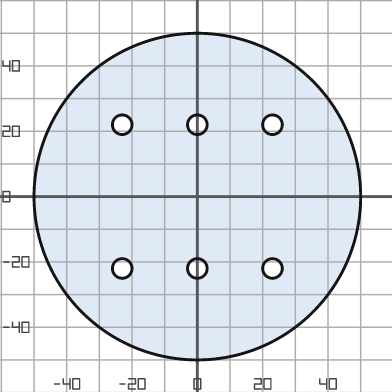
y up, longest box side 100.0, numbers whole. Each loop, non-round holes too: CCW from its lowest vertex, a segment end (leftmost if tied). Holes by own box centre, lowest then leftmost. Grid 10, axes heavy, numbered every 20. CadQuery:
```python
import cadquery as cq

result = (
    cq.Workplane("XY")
    .moveTo(0.0, 0.0)
    .circle(50.0)
    .moveTo(-23.0, -22.0)
    .circle(3.0)
    .moveTo(0.0, -22.0)
    .circle(3.0)
    .moveTo(23.0, -22.0)
    .circle(3.0)
    .moveTo(-23.0, 22.0)
    .circle(3.0)
    .moveTo(0.0, 22.0)
    .circle(3.0)
    .moveTo(23.0, 22.0)
    .circle(3.0)
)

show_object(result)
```